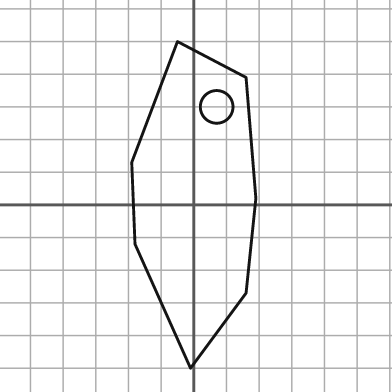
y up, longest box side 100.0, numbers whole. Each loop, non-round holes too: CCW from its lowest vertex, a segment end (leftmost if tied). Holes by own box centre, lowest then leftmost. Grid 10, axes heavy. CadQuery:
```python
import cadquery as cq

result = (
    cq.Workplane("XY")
    .moveTo(-1.0, -50.0)
    .lineTo(16.0, -27.0)
    .lineTo(19.0, 2.0)
    .lineTo(16.0, 39.0)
    .lineTo(-5.0, 50.0)
    .lineTo(-19.0, 13.0)
    .lineTo(-18.0, -12.0)
    .close()
    .moveTo(7.0, 30.0)
    .circle(5.0)
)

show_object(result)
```